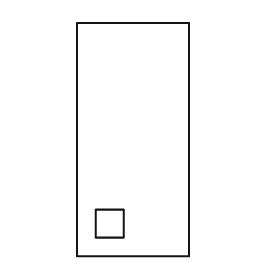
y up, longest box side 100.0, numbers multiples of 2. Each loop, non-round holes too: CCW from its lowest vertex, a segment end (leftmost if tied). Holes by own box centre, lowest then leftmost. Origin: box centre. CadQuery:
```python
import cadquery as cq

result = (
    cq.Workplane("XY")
    .moveTo(-24.0, -50.0)
    .lineTo(24.0, -50.0)
    .lineTo(24.0, 50.0)
    .lineTo(-24.0, 50.0)
    .close()
    .moveTo(-16.0, -42.0)
    .lineTo(-4.0, -42.0)
    .lineTo(-4.0, -30.0)
    .lineTo(-16.0, -30.0)
    .close()
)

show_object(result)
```